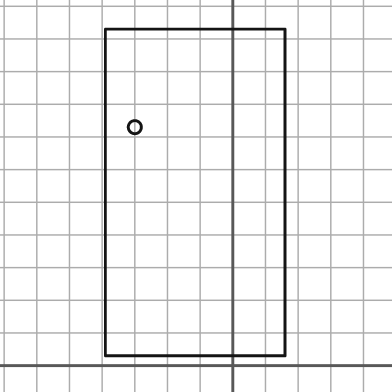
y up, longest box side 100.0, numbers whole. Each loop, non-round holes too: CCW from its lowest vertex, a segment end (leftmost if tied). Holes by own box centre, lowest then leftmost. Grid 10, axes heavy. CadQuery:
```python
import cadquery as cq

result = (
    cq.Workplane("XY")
    .moveTo(-39.0, 3.0)
    .lineTo(16.0, 3.0)
    .lineTo(16.0, 103.0)
    .lineTo(-39.0, 103.0)
    .close()
    .moveTo(-30.0, 73.0)
    .circle(2.0)
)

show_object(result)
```